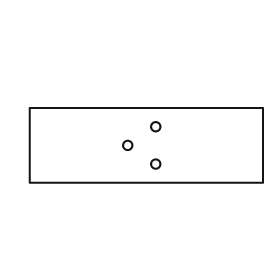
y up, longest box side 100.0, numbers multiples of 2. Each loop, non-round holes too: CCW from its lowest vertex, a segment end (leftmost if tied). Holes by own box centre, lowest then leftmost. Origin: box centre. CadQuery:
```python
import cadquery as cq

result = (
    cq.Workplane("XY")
    .moveTo(-50.0, -16.0)
    .lineTo(50.0, -16.0)
    .lineTo(50.0, 16.0)
    .lineTo(-50.0, 16.0)
    .close()
    .moveTo(4.0, -8.0)
    .circle(2.0)
    .moveTo(-8.0, 0.0)
    .circle(2.0)
    .moveTo(4.0, 8.0)
    .circle(2.0)
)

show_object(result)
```